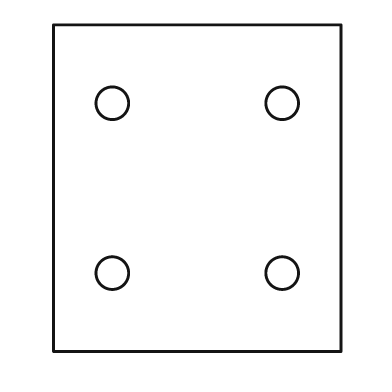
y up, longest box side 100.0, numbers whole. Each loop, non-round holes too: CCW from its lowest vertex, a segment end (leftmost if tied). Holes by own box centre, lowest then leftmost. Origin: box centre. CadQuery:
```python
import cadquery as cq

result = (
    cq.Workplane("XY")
    .moveTo(-44.0, -50.0)
    .lineTo(44.0, -50.0)
    .lineTo(44.0, 50.0)
    .lineTo(-44.0, 50.0)
    .close()
    .moveTo(-26.0, -26.0)
    .circle(5.0)
    .moveTo(26.0, -26.0)
    .circle(5.0)
    .moveTo(-26.0, 26.0)
    .circle(5.0)
    .moveTo(26.0, 26.0)
    .circle(5.0)
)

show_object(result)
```